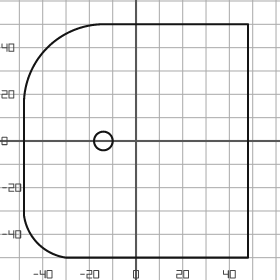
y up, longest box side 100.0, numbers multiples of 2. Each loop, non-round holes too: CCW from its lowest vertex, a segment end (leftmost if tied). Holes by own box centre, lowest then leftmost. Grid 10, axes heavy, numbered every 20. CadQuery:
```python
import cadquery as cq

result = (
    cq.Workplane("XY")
    .moveTo(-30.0, -50.0)
    .lineTo(48.0, -50.0)
    .lineTo(48.0, 50.0)
    .lineTo(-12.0, 50.0)
    .threePointArc((-38.0, 40.0), (-48.0, 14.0))
    .lineTo(-48.0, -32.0)
    .threePointArc((-42.0, -44.0), (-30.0, -50.0))
    .close()
    .moveTo(-14.0, 0.0)
    .circle(4.0)
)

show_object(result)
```